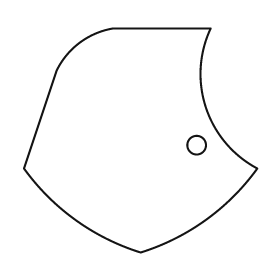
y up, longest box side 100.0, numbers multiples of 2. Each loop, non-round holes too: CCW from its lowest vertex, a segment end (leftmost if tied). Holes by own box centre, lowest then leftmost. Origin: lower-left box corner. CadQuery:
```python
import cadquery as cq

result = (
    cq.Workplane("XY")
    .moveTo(50.0, 0.0)
    .threePointArc((78.0, 14.0), (100.0, 36.0))
    .threePointArc((78.0, 62.0), (80.0, 96.0))
    .lineTo(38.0, 96.0)
    .threePointArc((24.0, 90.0), (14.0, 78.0))
    .lineTo(0.0, 36.0)
    .threePointArc((22.0, 14.0), (50.0, 0.0))
    .close()
    .moveTo(74.0, 46.0)
    .circle(4.0)
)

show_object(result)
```